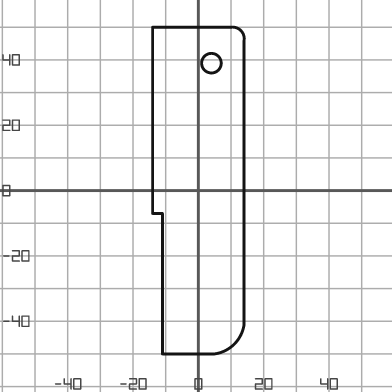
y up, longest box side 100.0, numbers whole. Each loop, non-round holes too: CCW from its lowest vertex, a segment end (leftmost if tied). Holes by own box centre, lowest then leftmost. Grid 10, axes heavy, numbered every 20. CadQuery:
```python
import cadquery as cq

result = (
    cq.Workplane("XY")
    .moveTo(-11.0, -50.0)
    .lineTo(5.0, -50.0)
    .threePointArc((11.0, -47.0), (14.0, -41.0))
    .lineTo(14.0, 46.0)
    .threePointArc((13.0, 49.0), (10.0, 50.0))
    .lineTo(-14.0, 50.0)
    .lineTo(-14.0, -7.0)
    .lineTo(-11.0, -7.0)
    .close()
    .moveTo(4.0, 39.0)
    .circle(3.0)
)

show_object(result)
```